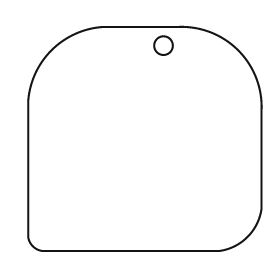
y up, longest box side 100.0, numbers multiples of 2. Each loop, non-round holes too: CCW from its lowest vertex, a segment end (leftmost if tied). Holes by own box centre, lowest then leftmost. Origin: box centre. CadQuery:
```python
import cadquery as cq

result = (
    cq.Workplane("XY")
    .moveTo(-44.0, -48.0)
    .lineTo(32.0, -48.0)
    .threePointArc((44.0, -42.0), (50.0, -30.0))
    .lineTo(50.0, 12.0)
    .threePointArc((40.0, 38.0), (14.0, 48.0))
    .lineTo(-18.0, 48.0)
    .threePointArc((-40.0, 38.0), (-50.0, 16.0))
    .lineTo(-50.0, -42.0)
    .threePointArc((-48.0, -46.0), (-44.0, -48.0))
    .close()
    .moveTo(8.0, 40.0)
    .circle(4.0)
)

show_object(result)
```